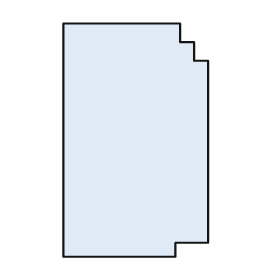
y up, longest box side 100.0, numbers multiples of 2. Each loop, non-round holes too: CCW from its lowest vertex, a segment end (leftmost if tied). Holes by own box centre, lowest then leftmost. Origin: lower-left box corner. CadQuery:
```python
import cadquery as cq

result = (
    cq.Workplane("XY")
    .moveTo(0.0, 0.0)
    .lineTo(48.0, 0.0)
    .lineTo(48.0, 6.0)
    .lineTo(62.0, 6.0)
    .lineTo(62.0, 84.0)
    .lineTo(56.0, 84.0)
    .lineTo(56.0, 92.0)
    .lineTo(50.0, 92.0)
    .lineTo(50.0, 100.0)
    .lineTo(0.0, 100.0)
    .close()
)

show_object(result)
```